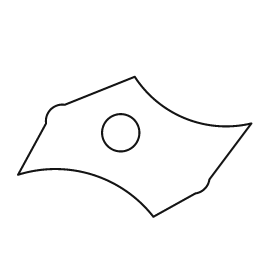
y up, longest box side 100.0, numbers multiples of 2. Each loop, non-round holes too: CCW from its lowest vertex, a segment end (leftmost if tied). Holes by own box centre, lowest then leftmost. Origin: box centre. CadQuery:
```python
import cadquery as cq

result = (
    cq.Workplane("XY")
    .moveTo(8.0, -30.0)
    .lineTo(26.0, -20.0)
    .threePointArc((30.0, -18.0), (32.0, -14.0))
    .lineTo(50.0, 10.0)
    .threePointArc((22.0, 12.0), (0.0, 30.0))
    .lineTo(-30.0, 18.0)
    .threePointArc((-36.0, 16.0), (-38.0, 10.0))
    .lineTo(-50.0, -12.0)
    .threePointArc((-18.0, -12.0), (8.0, -30.0))
    .close()
    .moveTo(-6.0, 6.0)
    .circle(8.0)
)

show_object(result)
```